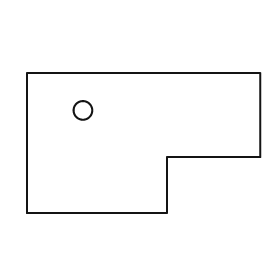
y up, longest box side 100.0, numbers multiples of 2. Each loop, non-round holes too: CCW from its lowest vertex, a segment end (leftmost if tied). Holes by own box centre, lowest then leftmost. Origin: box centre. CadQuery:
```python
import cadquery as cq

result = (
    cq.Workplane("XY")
    .moveTo(-50.0, -30.0)
    .lineTo(10.0, -30.0)
    .lineTo(10.0, -6.0)
    .lineTo(50.0, -6.0)
    .lineTo(50.0, 30.0)
    .lineTo(-50.0, 30.0)
    .close()
    .moveTo(-26.0, 14.0)
    .circle(4.0)
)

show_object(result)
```